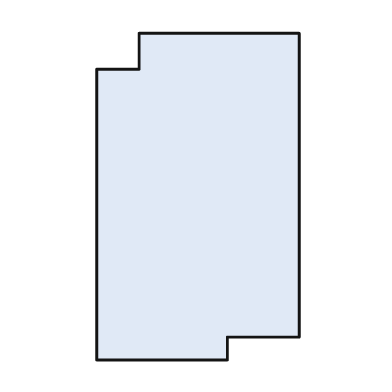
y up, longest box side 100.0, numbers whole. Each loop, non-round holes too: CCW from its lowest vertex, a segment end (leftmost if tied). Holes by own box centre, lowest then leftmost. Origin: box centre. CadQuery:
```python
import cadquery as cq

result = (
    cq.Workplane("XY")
    .moveTo(-31.0, -50.0)
    .lineTo(9.0, -50.0)
    .lineTo(9.0, -43.0)
    .lineTo(31.0, -43.0)
    .lineTo(31.0, 50.0)
    .lineTo(-18.0, 50.0)
    .lineTo(-18.0, 39.0)
    .lineTo(-31.0, 39.0)
    .close()
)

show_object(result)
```